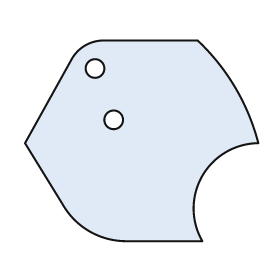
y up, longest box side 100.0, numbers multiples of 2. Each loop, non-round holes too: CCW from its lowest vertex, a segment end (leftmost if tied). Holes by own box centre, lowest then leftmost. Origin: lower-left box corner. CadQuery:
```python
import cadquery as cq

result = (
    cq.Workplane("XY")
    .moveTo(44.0, 0.0)
    .lineTo(76.0, 0.0)
    .threePointArc((76.0, 28.0), (100.0, 42.0))
    .threePointArc((90.0, 66.0), (74.0, 86.0))
    .lineTo(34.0, 86.0)
    .threePointArc((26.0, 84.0), (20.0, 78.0))
    .lineTo(0.0, 42.0)
    .lineTo(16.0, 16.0)
    .threePointArc((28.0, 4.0), (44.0, 0.0))
    .close()
    .moveTo(38.0, 52.0)
    .circle(4.0)
    .moveTo(30.0, 74.0)
    .circle(4.0)
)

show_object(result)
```